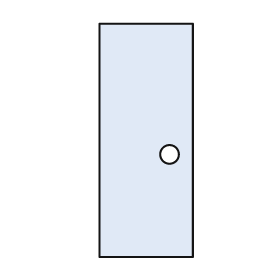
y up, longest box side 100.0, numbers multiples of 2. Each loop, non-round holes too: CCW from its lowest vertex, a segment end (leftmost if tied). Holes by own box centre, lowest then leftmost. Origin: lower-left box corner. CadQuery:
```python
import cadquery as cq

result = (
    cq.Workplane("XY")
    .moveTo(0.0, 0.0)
    .lineTo(40.0, 0.0)
    .lineTo(40.0, 100.0)
    .lineTo(0.0, 100.0)
    .close()
    .moveTo(30.0, 44.0)
    .circle(4.0)
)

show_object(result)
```